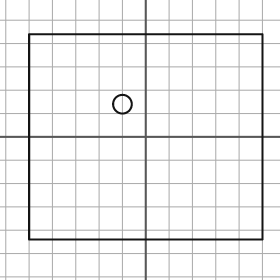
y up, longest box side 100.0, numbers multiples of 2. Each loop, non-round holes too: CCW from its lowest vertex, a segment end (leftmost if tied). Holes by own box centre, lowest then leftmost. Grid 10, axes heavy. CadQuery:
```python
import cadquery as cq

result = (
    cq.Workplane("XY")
    .moveTo(-50.0, -44.0)
    .lineTo(50.0, -44.0)
    .lineTo(50.0, 44.0)
    .lineTo(-50.0, 44.0)
    .close()
    .moveTo(-10.0, 14.0)
    .circle(4.0)
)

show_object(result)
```